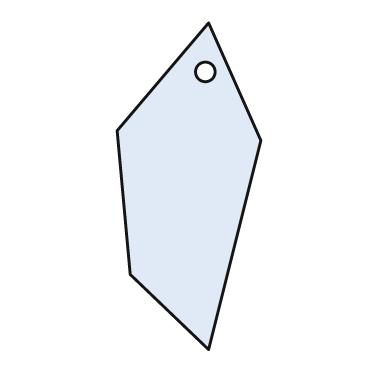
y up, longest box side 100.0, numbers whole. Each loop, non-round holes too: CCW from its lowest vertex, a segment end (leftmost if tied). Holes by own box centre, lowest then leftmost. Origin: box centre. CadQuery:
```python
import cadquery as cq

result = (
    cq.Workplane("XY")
    .moveTo(6.0, -50.0)
    .lineTo(22.0, 14.0)
    .lineTo(6.0, 50.0)
    .lineTo(-22.0, 17.0)
    .lineTo(-18.0, -27.0)
    .close()
    .moveTo(5.0, 35.0)
    .circle(3.0)
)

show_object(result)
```